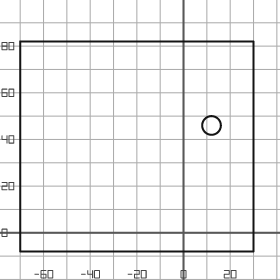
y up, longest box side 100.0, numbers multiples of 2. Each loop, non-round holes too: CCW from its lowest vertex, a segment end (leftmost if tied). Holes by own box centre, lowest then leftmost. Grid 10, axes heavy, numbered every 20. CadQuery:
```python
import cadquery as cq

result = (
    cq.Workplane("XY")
    .moveTo(-70.0, -8.0)
    .lineTo(30.0, -8.0)
    .lineTo(30.0, 82.0)
    .lineTo(-70.0, 82.0)
    .close()
    .moveTo(12.0, 46.0)
    .circle(4.0)
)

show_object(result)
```